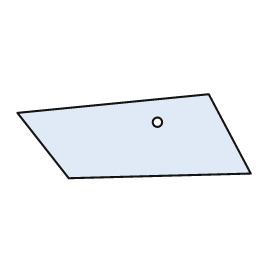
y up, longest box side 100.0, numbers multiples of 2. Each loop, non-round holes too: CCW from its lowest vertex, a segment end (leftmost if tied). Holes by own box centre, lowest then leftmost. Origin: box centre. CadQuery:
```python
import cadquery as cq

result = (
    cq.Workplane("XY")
    .moveTo(-28.0, -18.0)
    .lineTo(50.0, -16.0)
    .lineTo(32.0, 18.0)
    .lineTo(-50.0, 10.0)
    .close()
    .moveTo(10.0, 6.0)
    .circle(2.0)
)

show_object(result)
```